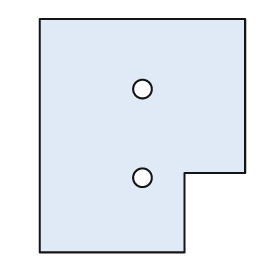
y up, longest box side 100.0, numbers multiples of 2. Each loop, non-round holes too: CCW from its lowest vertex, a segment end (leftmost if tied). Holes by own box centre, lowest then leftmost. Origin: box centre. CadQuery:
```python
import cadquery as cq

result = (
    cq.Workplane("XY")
    .moveTo(-44.0, -50.0)
    .lineTo(18.0, -50.0)
    .lineTo(18.0, -16.0)
    .lineTo(44.0, -16.0)
    .lineTo(44.0, 50.0)
    .lineTo(-44.0, 50.0)
    .close()
    .moveTo(0.0, -18.0)
    .circle(4.0)
    .moveTo(0.0, 20.0)
    .circle(4.0)
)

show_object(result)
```